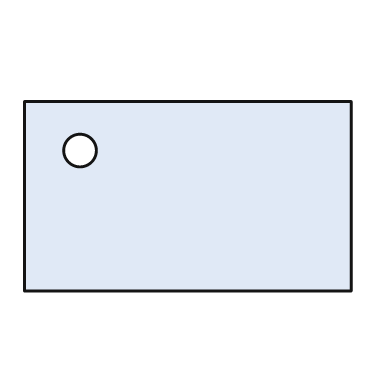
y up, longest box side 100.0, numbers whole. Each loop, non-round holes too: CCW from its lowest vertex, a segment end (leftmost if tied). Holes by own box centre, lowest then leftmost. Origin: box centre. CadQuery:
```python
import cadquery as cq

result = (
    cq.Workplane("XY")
    .moveTo(-50.0, -29.0)
    .lineTo(50.0, -29.0)
    .lineTo(50.0, 29.0)
    .lineTo(-50.0, 29.0)
    .close()
    .moveTo(-33.0, 14.0)
    .circle(5.0)
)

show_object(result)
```